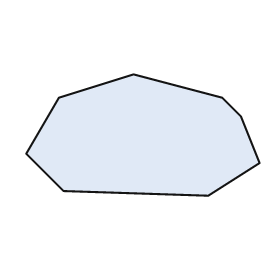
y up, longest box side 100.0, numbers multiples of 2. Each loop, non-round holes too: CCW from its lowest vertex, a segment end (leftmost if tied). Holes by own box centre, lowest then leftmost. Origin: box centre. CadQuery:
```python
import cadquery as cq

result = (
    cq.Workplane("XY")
    .moveTo(28.0, -26.0)
    .lineTo(50.0, -12.0)
    .lineTo(42.0, 8.0)
    .lineTo(34.0, 16.0)
    .lineTo(-4.0, 26.0)
    .lineTo(-36.0, 16.0)
    .lineTo(-50.0, -8.0)
    .lineTo(-34.0, -24.0)
    .close()
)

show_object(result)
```